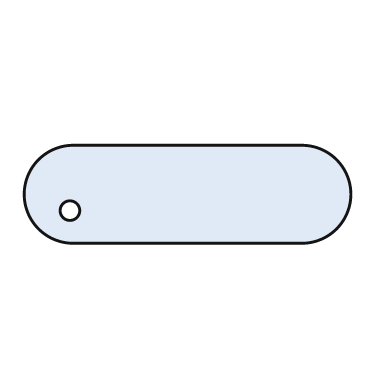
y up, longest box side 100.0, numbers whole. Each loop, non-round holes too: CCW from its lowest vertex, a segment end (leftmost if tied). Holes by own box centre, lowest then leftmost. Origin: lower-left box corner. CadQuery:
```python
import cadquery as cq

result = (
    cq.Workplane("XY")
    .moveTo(15.0, 0.0)
    .lineTo(85.0, 0.0)
    .threePointArc((100.0, 15.0), (85.0, 30.0))
    .lineTo(15.0, 30.0)
    .threePointArc((0.0, 15.0), (15.0, 0.0))
    .close()
    .moveTo(14.0, 10.0)
    .circle(3.0)
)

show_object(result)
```